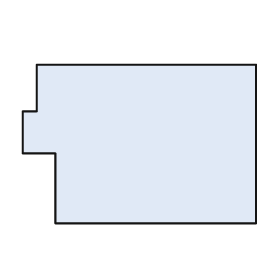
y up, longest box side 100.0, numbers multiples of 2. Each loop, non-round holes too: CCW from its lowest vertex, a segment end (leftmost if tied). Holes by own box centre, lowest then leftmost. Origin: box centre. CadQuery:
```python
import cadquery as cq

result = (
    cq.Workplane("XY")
    .moveTo(-36.0, -34.0)
    .lineTo(50.0, -34.0)
    .lineTo(50.0, 34.0)
    .lineTo(-44.0, 34.0)
    .lineTo(-44.0, 14.0)
    .lineTo(-50.0, 14.0)
    .lineTo(-50.0, -4.0)
    .lineTo(-36.0, -4.0)
    .close()
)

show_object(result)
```